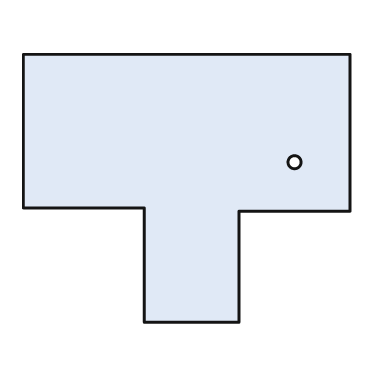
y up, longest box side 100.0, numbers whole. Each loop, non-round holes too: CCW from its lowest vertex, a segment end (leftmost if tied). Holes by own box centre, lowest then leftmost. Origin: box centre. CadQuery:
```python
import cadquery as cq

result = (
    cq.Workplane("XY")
    .moveTo(-13.0, -41.0)
    .lineTo(16.0, -41.0)
    .lineTo(16.0, -7.0)
    .lineTo(50.0, -7.0)
    .lineTo(50.0, 41.0)
    .lineTo(-50.0, 41.0)
    .lineTo(-50.0, -6.0)
    .lineTo(-13.0, -6.0)
    .close()
    .moveTo(33.0, 8.0)
    .circle(2.0)
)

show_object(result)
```